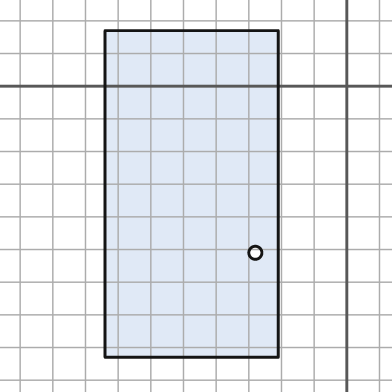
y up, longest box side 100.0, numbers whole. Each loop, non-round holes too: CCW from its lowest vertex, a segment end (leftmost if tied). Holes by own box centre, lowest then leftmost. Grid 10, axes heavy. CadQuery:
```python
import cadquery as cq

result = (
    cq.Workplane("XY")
    .moveTo(-74.0, -83.0)
    .lineTo(-21.0, -83.0)
    .lineTo(-21.0, 17.0)
    .lineTo(-74.0, 17.0)
    .close()
    .moveTo(-28.0, -51.0)
    .circle(2.0)
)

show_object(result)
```